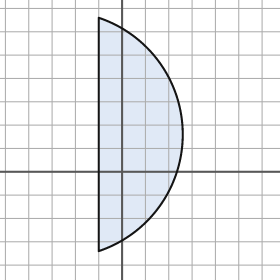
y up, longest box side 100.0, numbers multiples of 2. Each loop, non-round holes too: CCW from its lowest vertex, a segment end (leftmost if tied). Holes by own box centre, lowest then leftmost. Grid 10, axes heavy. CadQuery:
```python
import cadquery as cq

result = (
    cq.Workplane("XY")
    .moveTo(-10.0, -34.0)
    .threePointArc((26.0, 16.0), (-10.0, 66.0))
    .close()
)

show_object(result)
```